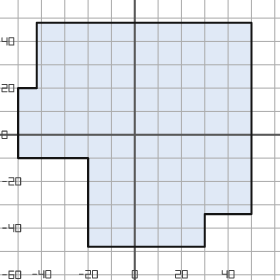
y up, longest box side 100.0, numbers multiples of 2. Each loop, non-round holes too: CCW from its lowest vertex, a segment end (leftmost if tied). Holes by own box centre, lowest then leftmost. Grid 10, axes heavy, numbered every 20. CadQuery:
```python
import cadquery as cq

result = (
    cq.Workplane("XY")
    .moveTo(-20.0, -48.0)
    .lineTo(30.0, -48.0)
    .lineTo(30.0, -34.0)
    .lineTo(50.0, -34.0)
    .lineTo(50.0, 48.0)
    .lineTo(-42.0, 48.0)
    .lineTo(-42.0, 20.0)
    .lineTo(-50.0, 20.0)
    .lineTo(-50.0, -10.0)
    .lineTo(-20.0, -10.0)
    .close()
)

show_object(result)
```